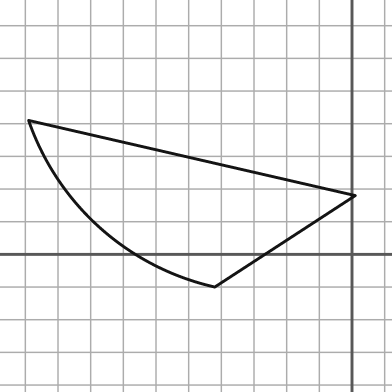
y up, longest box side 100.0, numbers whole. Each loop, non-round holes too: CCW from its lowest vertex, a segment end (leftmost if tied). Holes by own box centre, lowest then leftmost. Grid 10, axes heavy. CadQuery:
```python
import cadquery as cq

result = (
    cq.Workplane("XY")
    .moveTo(-42.0, -10.0)
    .lineTo(1.0, 18.0)
    .lineTo(-99.0, 41.0)
    .threePointArc((-77.0, 8.0), (-42.0, -10.0))
    .close()
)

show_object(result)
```